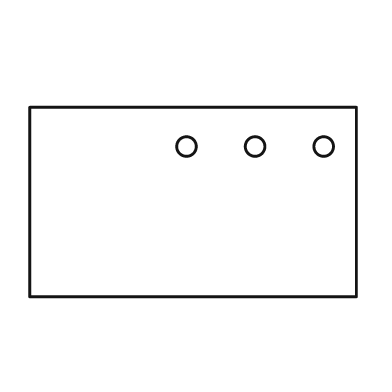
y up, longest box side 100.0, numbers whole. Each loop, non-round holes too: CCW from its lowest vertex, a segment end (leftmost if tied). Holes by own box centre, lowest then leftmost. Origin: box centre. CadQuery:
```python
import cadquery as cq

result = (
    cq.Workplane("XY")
    .moveTo(-50.0, -29.0)
    .lineTo(50.0, -29.0)
    .lineTo(50.0, 29.0)
    .lineTo(-50.0, 29.0)
    .close()
    .moveTo(-2.0, 17.0)
    .circle(3.0)
    .moveTo(19.0, 17.0)
    .circle(3.0)
    .moveTo(40.0, 17.0)
    .circle(3.0)
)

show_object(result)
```